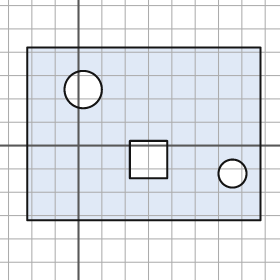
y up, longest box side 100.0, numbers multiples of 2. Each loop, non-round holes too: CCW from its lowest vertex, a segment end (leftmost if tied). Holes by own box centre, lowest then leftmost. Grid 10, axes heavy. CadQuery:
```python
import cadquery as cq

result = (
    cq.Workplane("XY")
    .moveTo(-22.0, -32.0)
    .lineTo(78.0, -32.0)
    .lineTo(78.0, 42.0)
    .lineTo(-22.0, 42.0)
    .close()
    .moveTo(66.0, -12.0)
    .circle(6.0)
    .moveTo(22.0, -14.0)
    .lineTo(38.0, -14.0)
    .lineTo(38.0, 2.0)
    .lineTo(22.0, 2.0)
    .close()
    .moveTo(2.0, 24.0)
    .circle(8.0)
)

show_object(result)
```